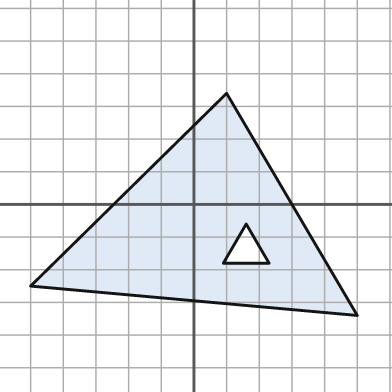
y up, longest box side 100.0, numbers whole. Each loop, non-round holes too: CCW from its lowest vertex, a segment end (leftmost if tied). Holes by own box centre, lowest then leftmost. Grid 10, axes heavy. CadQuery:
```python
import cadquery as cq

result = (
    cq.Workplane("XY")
    .moveTo(50.0, -34.0)
    .lineTo(10.0, 34.0)
    .lineTo(-50.0, -25.0)
    .close()
    .moveTo(9.0, -18.0)
    .lineTo(23.0, -18.0)
    .lineTo(16.0, -6.0)
    .close()
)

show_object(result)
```